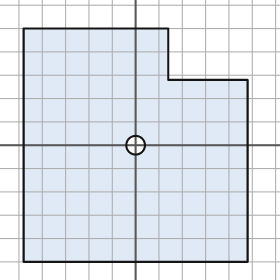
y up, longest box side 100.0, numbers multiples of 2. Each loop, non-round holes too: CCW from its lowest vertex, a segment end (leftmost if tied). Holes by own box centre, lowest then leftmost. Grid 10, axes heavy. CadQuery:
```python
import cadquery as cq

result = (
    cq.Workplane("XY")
    .moveTo(-48.0, -50.0)
    .lineTo(48.0, -50.0)
    .lineTo(48.0, 28.0)
    .lineTo(14.0, 28.0)
    .lineTo(14.0, 50.0)
    .lineTo(-48.0, 50.0)
    .close()
    .moveTo(0.0, 0.0)
    .circle(4.0)
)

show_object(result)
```